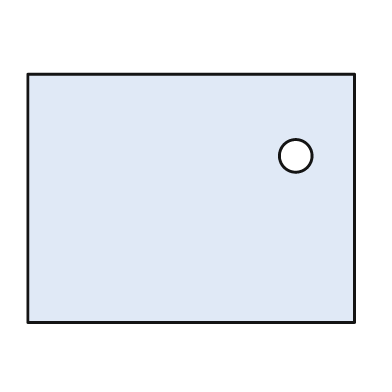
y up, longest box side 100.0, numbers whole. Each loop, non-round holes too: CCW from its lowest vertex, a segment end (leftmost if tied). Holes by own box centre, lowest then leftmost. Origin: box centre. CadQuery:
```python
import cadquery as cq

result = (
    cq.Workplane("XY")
    .moveTo(-50.0, -38.0)
    .lineTo(50.0, -38.0)
    .lineTo(50.0, 38.0)
    .lineTo(-50.0, 38.0)
    .close()
    .moveTo(32.0, 13.0)
    .circle(5.0)
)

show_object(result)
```